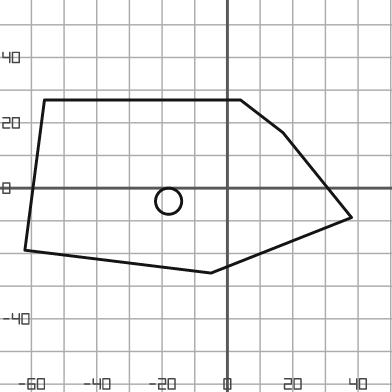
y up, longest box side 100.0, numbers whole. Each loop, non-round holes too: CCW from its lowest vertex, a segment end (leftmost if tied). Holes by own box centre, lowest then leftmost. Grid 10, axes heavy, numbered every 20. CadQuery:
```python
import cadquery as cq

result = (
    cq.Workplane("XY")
    .moveTo(-5.0, -26.0)
    .lineTo(38.0, -9.0)
    .lineTo(17.0, 17.0)
    .lineTo(4.0, 27.0)
    .lineTo(-56.0, 27.0)
    .lineTo(-62.0, -19.0)
    .close()
    .moveTo(-18.0, -4.0)
    .circle(4.0)
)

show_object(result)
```